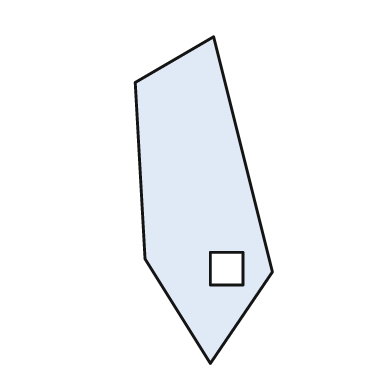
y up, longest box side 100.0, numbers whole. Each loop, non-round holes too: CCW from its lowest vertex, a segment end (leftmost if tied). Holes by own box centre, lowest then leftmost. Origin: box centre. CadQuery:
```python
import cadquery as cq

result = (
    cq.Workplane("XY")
    .moveTo(2.0, -50.0)
    .lineTo(21.0, -22.0)
    .lineTo(3.0, 50.0)
    .lineTo(-21.0, 36.0)
    .lineTo(-18.0, -18.0)
    .close()
    .moveTo(2.0, -26.0)
    .lineTo(12.0, -26.0)
    .lineTo(12.0, -16.0)
    .lineTo(2.0, -16.0)
    .close()
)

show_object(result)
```